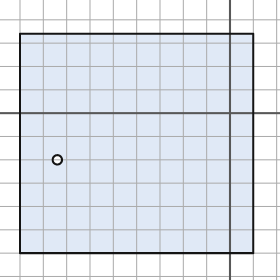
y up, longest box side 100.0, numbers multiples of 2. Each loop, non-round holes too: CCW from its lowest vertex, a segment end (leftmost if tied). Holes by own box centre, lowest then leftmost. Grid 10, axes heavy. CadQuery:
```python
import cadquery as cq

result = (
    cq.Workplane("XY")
    .moveTo(-90.0, -60.0)
    .lineTo(10.0, -60.0)
    .lineTo(10.0, 34.0)
    .lineTo(-90.0, 34.0)
    .close()
    .moveTo(-74.0, -20.0)
    .circle(2.0)
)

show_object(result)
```